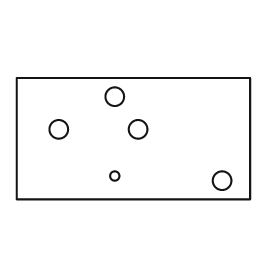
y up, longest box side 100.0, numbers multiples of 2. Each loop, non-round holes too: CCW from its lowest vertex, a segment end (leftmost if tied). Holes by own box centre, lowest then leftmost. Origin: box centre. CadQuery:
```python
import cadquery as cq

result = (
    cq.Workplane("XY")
    .moveTo(-50.0, -26.0)
    .lineTo(50.0, -26.0)
    .lineTo(50.0, 26.0)
    .lineTo(-50.0, 26.0)
    .close()
    .moveTo(38.0, -18.0)
    .circle(4.0)
    .moveTo(-8.0, -16.0)
    .circle(2.0)
    .moveTo(-32.0, 4.0)
    .circle(4.0)
    .moveTo(2.0, 4.0)
    .circle(4.0)
    .moveTo(-8.0, 18.0)
    .circle(4.0)
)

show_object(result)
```